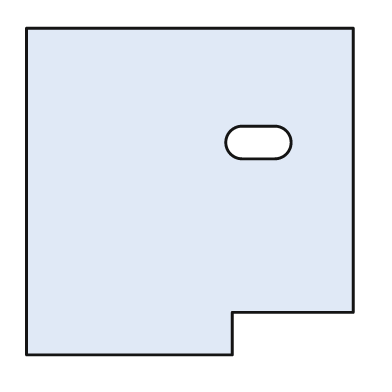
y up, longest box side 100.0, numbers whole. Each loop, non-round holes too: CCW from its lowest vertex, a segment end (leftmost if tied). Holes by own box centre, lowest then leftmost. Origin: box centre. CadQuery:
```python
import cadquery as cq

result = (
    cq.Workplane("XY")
    .moveTo(-50.0, -50.0)
    .lineTo(13.0, -50.0)
    .lineTo(13.0, -37.0)
    .lineTo(50.0, -37.0)
    .lineTo(50.0, 50.0)
    .lineTo(-50.0, 50.0)
    .close()
    .moveTo(16.0, 10.0)
    .lineTo(26.0, 10.0)
    .threePointArc((31.0, 15.0), (26.0, 20.0))
    .lineTo(16.0, 20.0)
    .threePointArc((11.0, 15.0), (16.0, 10.0))
    .close()
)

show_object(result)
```